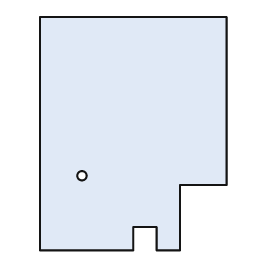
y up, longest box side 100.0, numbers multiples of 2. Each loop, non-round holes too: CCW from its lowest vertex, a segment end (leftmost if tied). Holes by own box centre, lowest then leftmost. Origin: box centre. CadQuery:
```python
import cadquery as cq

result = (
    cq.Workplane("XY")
    .moveTo(-40.0, -50.0)
    .lineTo(0.0, -50.0)
    .lineTo(0.0, -40.0)
    .lineTo(10.0, -40.0)
    .lineTo(10.0, -50.0)
    .lineTo(20.0, -50.0)
    .lineTo(20.0, -22.0)
    .lineTo(40.0, -22.0)
    .lineTo(40.0, 50.0)
    .lineTo(-40.0, 50.0)
    .close()
    .moveTo(-22.0, -18.0)
    .circle(2.0)
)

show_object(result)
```